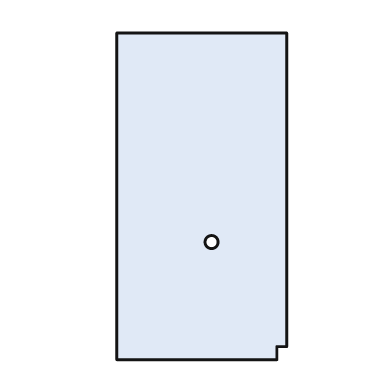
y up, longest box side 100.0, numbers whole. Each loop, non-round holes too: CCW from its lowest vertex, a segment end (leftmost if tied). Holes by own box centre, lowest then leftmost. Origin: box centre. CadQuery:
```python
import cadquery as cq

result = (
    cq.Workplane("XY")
    .moveTo(-26.0, -50.0)
    .lineTo(23.0, -50.0)
    .lineTo(23.0, -46.0)
    .lineTo(26.0, -46.0)
    .lineTo(26.0, 50.0)
    .lineTo(-26.0, 50.0)
    .close()
    .moveTo(3.0, -14.0)
    .circle(2.0)
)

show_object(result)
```